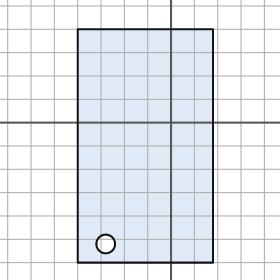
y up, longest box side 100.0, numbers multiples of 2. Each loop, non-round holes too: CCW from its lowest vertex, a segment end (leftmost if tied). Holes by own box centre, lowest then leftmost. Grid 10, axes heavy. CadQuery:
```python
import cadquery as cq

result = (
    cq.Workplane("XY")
    .moveTo(-40.0, -60.0)
    .lineTo(18.0, -60.0)
    .lineTo(18.0, 40.0)
    .lineTo(-40.0, 40.0)
    .close()
    .moveTo(-28.0, -52.0)
    .circle(4.0)
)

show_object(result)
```